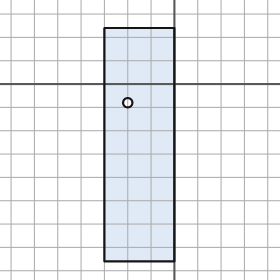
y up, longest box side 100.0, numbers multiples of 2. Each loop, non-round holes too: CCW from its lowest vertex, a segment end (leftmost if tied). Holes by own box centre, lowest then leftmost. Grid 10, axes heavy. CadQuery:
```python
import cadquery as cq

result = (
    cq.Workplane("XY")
    .moveTo(-30.0, -76.0)
    .lineTo(0.0, -76.0)
    .lineTo(0.0, 24.0)
    .lineTo(-30.0, 24.0)
    .close()
    .moveTo(-20.0, -8.0)
    .circle(2.0)
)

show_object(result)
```